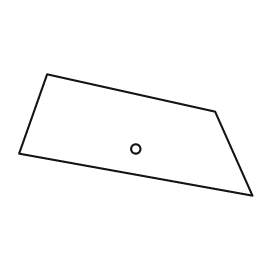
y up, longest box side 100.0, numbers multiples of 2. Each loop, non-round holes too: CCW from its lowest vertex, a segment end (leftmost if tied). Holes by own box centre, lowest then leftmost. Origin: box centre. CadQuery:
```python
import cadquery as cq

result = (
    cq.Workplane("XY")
    .moveTo(50.0, -26.0)
    .lineTo(34.0, 10.0)
    .lineTo(-38.0, 26.0)
    .lineTo(-50.0, -8.0)
    .close()
    .moveTo(0.0, -6.0)
    .circle(2.0)
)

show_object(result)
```